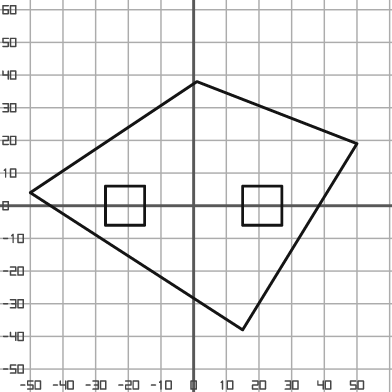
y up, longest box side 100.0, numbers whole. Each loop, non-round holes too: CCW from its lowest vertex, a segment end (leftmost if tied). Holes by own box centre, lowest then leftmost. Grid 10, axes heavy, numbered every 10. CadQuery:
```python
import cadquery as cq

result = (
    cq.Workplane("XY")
    .moveTo(15.0, -38.0)
    .lineTo(50.0, 19.0)
    .lineTo(1.0, 38.0)
    .lineTo(-50.0, 4.0)
    .close()
    .moveTo(-27.0, -6.0)
    .lineTo(-15.0, -6.0)
    .lineTo(-15.0, 6.0)
    .lineTo(-27.0, 6.0)
    .close()
    .moveTo(15.0, -6.0)
    .lineTo(27.0, -6.0)
    .lineTo(27.0, 6.0)
    .lineTo(15.0, 6.0)
    .close()
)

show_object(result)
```